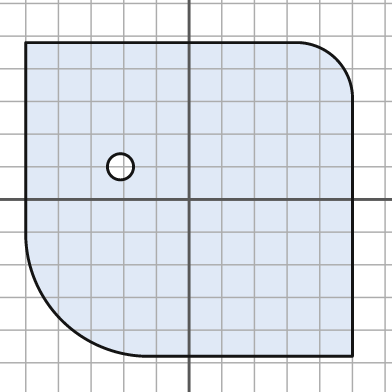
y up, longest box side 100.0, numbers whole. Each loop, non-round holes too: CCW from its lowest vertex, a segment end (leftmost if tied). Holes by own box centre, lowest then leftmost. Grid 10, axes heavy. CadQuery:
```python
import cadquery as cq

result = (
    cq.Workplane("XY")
    .moveTo(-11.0, -48.0)
    .lineTo(50.0, -48.0)
    .lineTo(50.0, 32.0)
    .threePointArc((45.0, 43.0), (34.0, 48.0))
    .lineTo(-50.0, 48.0)
    .lineTo(-50.0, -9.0)
    .threePointArc((-39.0, -37.0), (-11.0, -48.0))
    .close()
    .moveTo(-21.0, 10.0)
    .circle(4.0)
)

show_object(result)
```